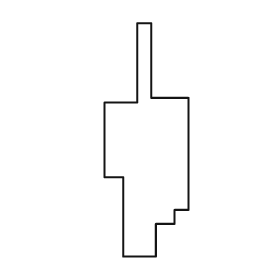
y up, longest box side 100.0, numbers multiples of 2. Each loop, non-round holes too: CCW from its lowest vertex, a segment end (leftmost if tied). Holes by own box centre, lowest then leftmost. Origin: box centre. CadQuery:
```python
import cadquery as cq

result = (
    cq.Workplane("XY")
    .moveTo(-10.0, -50.0)
    .lineTo(4.0, -50.0)
    .lineTo(4.0, -36.0)
    .lineTo(12.0, -36.0)
    .lineTo(12.0, -30.0)
    .lineTo(18.0, -30.0)
    .lineTo(18.0, 18.0)
    .lineTo(2.0, 18.0)
    .lineTo(2.0, 50.0)
    .lineTo(-4.0, 50.0)
    .lineTo(-4.0, 16.0)
    .lineTo(-18.0, 16.0)
    .lineTo(-18.0, -16.0)
    .lineTo(-10.0, -16.0)
    .close()
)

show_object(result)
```